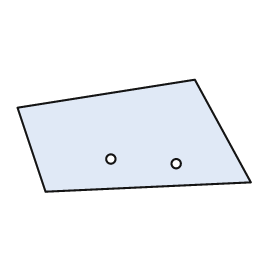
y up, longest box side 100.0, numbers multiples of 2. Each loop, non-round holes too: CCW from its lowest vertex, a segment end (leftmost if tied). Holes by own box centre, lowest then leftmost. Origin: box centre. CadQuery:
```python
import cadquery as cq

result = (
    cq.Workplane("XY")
    .moveTo(-38.0, -24.0)
    .lineTo(50.0, -20.0)
    .lineTo(26.0, 24.0)
    .lineTo(-50.0, 12.0)
    .close()
    .moveTo(18.0, -12.0)
    .circle(2.0)
    .moveTo(-10.0, -10.0)
    .circle(2.0)
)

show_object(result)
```